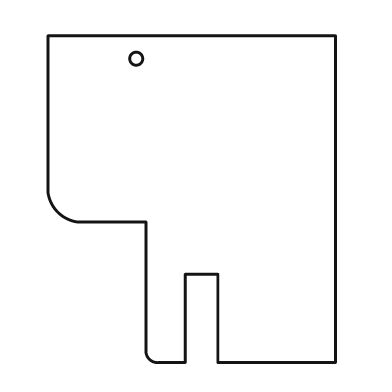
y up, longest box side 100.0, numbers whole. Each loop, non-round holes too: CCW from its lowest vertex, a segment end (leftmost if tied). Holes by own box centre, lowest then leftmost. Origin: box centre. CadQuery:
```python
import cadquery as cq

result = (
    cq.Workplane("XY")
    .moveTo(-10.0, -50.0)
    .lineTo(-2.0, -50.0)
    .lineTo(-2.0, -23.0)
    .lineTo(8.0, -23.0)
    .lineTo(8.0, -50.0)
    .lineTo(44.0, -50.0)
    .lineTo(44.0, 50.0)
    .lineTo(-44.0, 50.0)
    .lineTo(-44.0, 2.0)
    .threePointArc((-41.0, -4.0), (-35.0, -7.0))
    .lineTo(-14.0, -7.0)
    .lineTo(-14.0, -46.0)
    .threePointArc((-13.0, -49.0), (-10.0, -50.0))
    .close()
    .moveTo(-17.0, 43.0)
    .circle(2.0)
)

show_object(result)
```